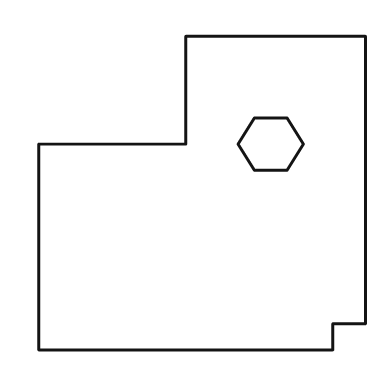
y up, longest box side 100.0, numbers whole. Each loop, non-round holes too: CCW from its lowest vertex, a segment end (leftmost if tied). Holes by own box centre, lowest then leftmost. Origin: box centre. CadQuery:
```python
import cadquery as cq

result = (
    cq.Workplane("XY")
    .moveTo(-50.0, -48.0)
    .lineTo(40.0, -48.0)
    .lineTo(40.0, -40.0)
    .lineTo(50.0, -40.0)
    .lineTo(50.0, 48.0)
    .lineTo(-5.0, 48.0)
    .lineTo(-5.0, 15.0)
    .lineTo(-50.0, 15.0)
    .close()
    .moveTo(16.0, 7.0)
    .lineTo(26.0, 7.0)
    .lineTo(31.0, 15.0)
    .lineTo(26.0, 23.0)
    .lineTo(16.0, 23.0)
    .lineTo(11.0, 15.0)
    .close()
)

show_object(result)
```